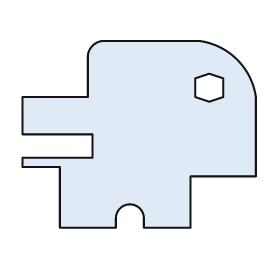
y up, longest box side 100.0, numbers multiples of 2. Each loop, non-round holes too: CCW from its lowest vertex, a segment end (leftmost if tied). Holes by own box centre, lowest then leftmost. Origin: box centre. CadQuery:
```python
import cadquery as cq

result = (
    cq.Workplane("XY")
    .moveTo(-34.0, -40.0)
    .lineTo(-10.0, -40.0)
    .lineTo(-10.0, -36.0)
    .threePointArc((-4.0, -30.0), (2.0, -36.0))
    .lineTo(2.0, -40.0)
    .lineTo(22.0, -40.0)
    .lineTo(22.0, -18.0)
    .lineTo(50.0, -18.0)
    .lineTo(50.0, 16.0)
    .threePointArc((42.0, 32.0), (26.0, 40.0))
    .lineTo(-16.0, 40.0)
    .threePointArc((-20.0, 38.0), (-22.0, 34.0))
    .lineTo(-22.0, 16.0)
    .lineTo(-50.0, 16.0)
    .lineTo(-50.0, 0.0)
    .lineTo(-20.0, 0.0)
    .lineTo(-20.0, -10.0)
    .lineTo(-50.0, -10.0)
    .lineTo(-50.0, -14.0)
    .lineTo(-34.0, -14.0)
    .close()
    .moveTo(30.0, 14.0)
    .lineTo(36.0, 16.0)
    .lineTo(36.0, 24.0)
    .lineTo(30.0, 26.0)
    .lineTo(24.0, 24.0)
    .lineTo(24.0, 16.0)
    .close()
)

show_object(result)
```